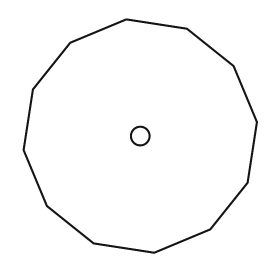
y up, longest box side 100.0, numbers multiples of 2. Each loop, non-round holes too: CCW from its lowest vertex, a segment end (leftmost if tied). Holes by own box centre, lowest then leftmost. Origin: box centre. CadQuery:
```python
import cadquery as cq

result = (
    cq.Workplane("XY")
    .moveTo(6.0, -50.0)
    .lineTo(30.0, -40.0)
    .lineTo(46.0, -20.0)
    .lineTo(50.0, 6.0)
    .lineTo(40.0, 30.0)
    .lineTo(20.0, 46.0)
    .lineTo(-6.0, 50.0)
    .lineTo(-30.0, 40.0)
    .lineTo(-46.0, 20.0)
    .lineTo(-50.0, -6.0)
    .lineTo(-40.0, -30.0)
    .lineTo(-20.0, -46.0)
    .close()
    .moveTo(0.0, 0.0)
    .circle(4.0)
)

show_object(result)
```